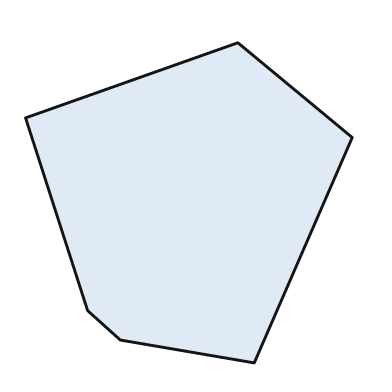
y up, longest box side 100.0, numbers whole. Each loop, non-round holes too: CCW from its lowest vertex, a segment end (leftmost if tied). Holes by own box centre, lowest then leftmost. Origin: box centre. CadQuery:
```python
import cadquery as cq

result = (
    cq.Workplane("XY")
    .moveTo(20.0, -49.0)
    .lineTo(50.0, 20.0)
    .lineTo(15.0, 49.0)
    .lineTo(-50.0, 26.0)
    .lineTo(-31.0, -33.0)
    .lineTo(-21.0, -42.0)
    .close()
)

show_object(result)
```